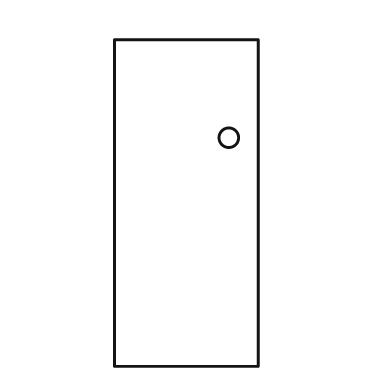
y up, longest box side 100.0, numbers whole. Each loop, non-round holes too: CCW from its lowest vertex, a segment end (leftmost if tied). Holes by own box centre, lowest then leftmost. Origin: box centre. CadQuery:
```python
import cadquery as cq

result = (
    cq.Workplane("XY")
    .moveTo(-22.0, -50.0)
    .lineTo(22.0, -50.0)
    .lineTo(22.0, 50.0)
    .lineTo(-22.0, 50.0)
    .close()
    .moveTo(13.0, 20.0)
    .circle(3.0)
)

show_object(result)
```